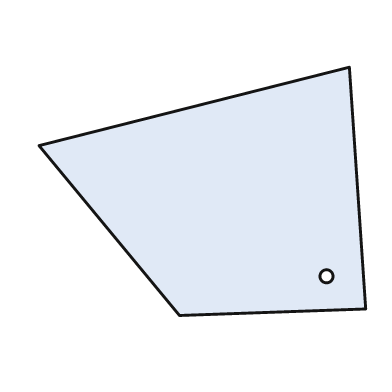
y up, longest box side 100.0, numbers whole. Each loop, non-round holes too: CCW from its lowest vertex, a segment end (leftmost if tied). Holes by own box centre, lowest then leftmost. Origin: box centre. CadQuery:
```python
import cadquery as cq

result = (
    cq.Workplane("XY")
    .moveTo(-7.0, -38.0)
    .lineTo(50.0, -36.0)
    .lineTo(45.0, 38.0)
    .lineTo(-50.0, 14.0)
    .close()
    .moveTo(38.0, -26.0)
    .circle(2.0)
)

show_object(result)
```